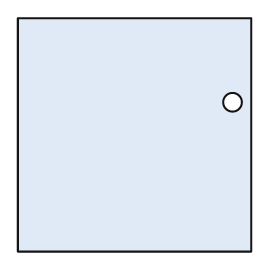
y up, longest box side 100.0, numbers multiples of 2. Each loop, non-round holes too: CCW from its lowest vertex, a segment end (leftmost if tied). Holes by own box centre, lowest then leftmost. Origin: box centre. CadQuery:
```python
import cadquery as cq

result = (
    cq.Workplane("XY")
    .moveTo(-50.0, -50.0)
    .lineTo(50.0, -50.0)
    .lineTo(50.0, 50.0)
    .lineTo(-50.0, 50.0)
    .close()
    .moveTo(42.0, 14.0)
    .circle(4.0)
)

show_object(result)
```